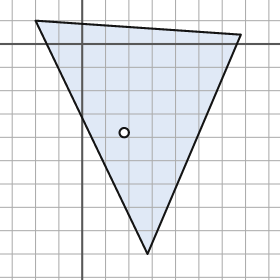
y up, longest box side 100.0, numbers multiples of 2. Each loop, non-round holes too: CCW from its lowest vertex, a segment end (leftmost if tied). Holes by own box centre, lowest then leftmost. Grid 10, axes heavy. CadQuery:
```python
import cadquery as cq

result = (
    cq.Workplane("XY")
    .moveTo(28.0, -90.0)
    .lineTo(68.0, 4.0)
    .lineTo(-20.0, 10.0)
    .close()
    .moveTo(18.0, -38.0)
    .circle(2.0)
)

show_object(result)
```